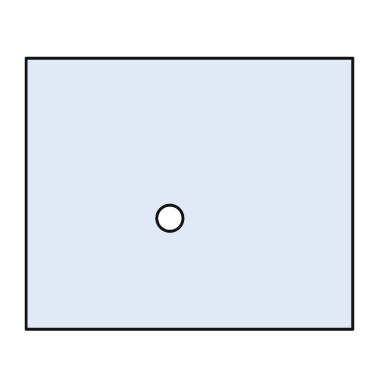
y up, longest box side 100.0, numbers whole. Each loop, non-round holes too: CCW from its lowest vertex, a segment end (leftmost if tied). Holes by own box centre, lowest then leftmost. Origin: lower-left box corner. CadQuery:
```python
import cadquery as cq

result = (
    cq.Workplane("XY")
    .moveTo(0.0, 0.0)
    .lineTo(100.0, 0.0)
    .lineTo(100.0, 83.0)
    .lineTo(0.0, 83.0)
    .close()
    .moveTo(44.0, 34.0)
    .circle(4.0)
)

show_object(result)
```